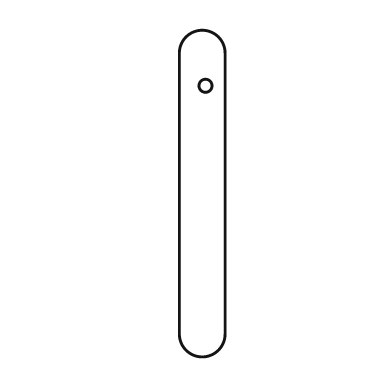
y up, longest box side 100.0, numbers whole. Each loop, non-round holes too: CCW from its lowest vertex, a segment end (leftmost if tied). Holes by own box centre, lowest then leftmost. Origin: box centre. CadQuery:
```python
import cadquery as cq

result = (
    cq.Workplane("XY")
    .moveTo(-7.0, -43.0)
    .threePointArc((0.0, -50.0), (7.0, -43.0))
    .lineTo(7.0, 43.0)
    .threePointArc((0.0, 50.0), (-7.0, 43.0))
    .close()
    .moveTo(1.0, 33.0)
    .circle(2.0)
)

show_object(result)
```